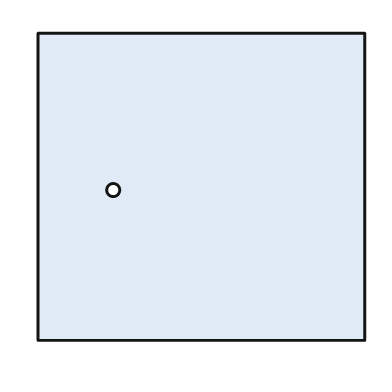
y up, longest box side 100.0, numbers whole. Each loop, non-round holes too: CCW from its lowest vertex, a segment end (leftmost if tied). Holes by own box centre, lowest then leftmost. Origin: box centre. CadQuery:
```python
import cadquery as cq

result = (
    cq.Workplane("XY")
    .moveTo(-50.0, -47.0)
    .lineTo(50.0, -47.0)
    .lineTo(50.0, 47.0)
    .lineTo(-50.0, 47.0)
    .close()
    .moveTo(-27.0, -1.0)
    .circle(2.0)
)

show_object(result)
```